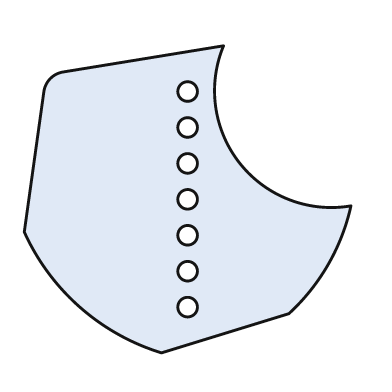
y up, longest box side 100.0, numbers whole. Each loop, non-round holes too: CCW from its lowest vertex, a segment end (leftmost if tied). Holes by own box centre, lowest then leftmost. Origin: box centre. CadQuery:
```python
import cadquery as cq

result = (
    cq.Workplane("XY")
    .moveTo(-8.0, -47.0)
    .lineTo(31.0, -35.0)
    .threePointArc((43.0, -20.0), (50.0, -2.0))
    .threePointArc((16.0, 11.0), (11.0, 47.0))
    .lineTo(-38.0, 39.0)
    .threePointArc((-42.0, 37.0), (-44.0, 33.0))
    .lineTo(-50.0, -10.0)
    .threePointArc((-33.0, -33.0), (-8.0, -47.0))
    .close()
    .moveTo(0.0, -33.0)
    .circle(3.0)
    .moveTo(0.0, -22.0)
    .circle(3.0)
    .moveTo(0.0, -11.0)
    .circle(3.0)
    .moveTo(0.0, 0.0)
    .circle(3.0)
    .moveTo(0.0, 11.0)
    .circle(3.0)
    .moveTo(0.0, 22.0)
    .circle(3.0)
    .moveTo(0.0, 33.0)
    .circle(3.0)
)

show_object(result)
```